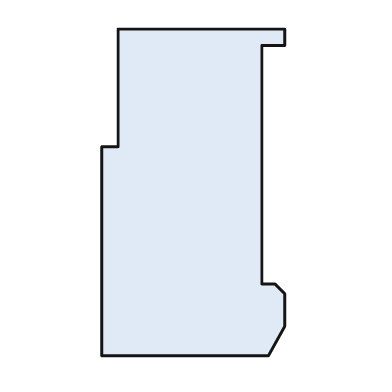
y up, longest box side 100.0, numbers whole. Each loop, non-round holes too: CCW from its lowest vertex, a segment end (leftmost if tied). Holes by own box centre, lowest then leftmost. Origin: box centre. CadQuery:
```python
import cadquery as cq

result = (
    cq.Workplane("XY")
    .moveTo(-28.0, -50.0)
    .lineTo(23.0, -50.0)
    .lineTo(28.0, -41.0)
    .lineTo(28.0, -31.0)
    .lineTo(25.0, -28.0)
    .lineTo(21.0, -28.0)
    .lineTo(21.0, 45.0)
    .lineTo(28.0, 45.0)
    .lineTo(28.0, 50.0)
    .lineTo(-23.0, 50.0)
    .lineTo(-23.0, 14.0)
    .lineTo(-28.0, 14.0)
    .close()
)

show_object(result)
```